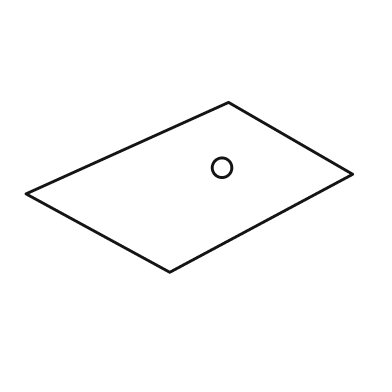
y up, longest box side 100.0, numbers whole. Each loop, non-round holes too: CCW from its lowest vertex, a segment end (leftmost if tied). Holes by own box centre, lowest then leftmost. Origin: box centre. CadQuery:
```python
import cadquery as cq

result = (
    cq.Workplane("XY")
    .moveTo(-6.0, -26.0)
    .lineTo(50.0, 4.0)
    .lineTo(12.0, 26.0)
    .lineTo(-50.0, -2.0)
    .close()
    .moveTo(10.0, 6.0)
    .circle(3.0)
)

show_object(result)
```